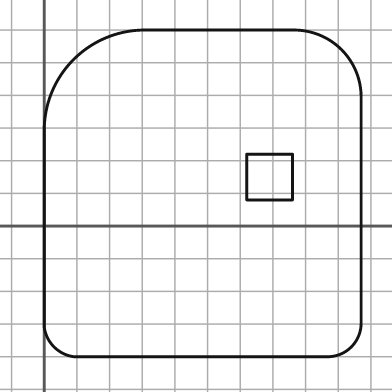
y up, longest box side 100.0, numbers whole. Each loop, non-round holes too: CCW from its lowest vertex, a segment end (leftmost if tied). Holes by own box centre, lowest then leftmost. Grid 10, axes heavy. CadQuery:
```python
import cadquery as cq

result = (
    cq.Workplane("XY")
    .moveTo(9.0, -40.0)
    .lineTo(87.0, -40.0)
    .threePointArc((94.0, -37.0), (97.0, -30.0))
    .lineTo(97.0, 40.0)
    .threePointArc((91.0, 54.0), (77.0, 60.0))
    .lineTo(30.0, 60.0)
    .threePointArc((9.0, 51.0), (0.0, 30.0))
    .lineTo(0.0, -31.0)
    .threePointArc((3.0, -37.0), (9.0, -40.0))
    .close()
    .moveTo(62.0, 8.0)
    .lineTo(76.0, 8.0)
    .lineTo(76.0, 22.0)
    .lineTo(62.0, 22.0)
    .close()
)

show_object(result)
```